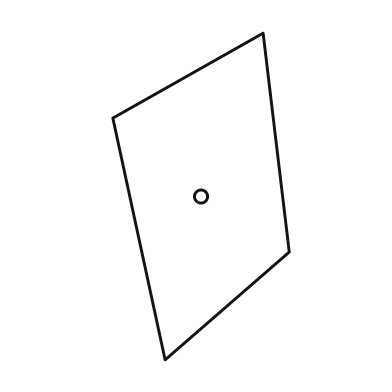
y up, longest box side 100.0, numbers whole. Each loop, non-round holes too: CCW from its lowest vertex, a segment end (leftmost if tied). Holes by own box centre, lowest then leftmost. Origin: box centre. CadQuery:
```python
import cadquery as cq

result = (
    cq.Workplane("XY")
    .moveTo(-11.0, -50.0)
    .lineTo(27.0, -17.0)
    .lineTo(19.0, 50.0)
    .lineTo(-27.0, 24.0)
    .close()
    .moveTo(0.0, 0.0)
    .circle(2.0)
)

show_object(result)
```